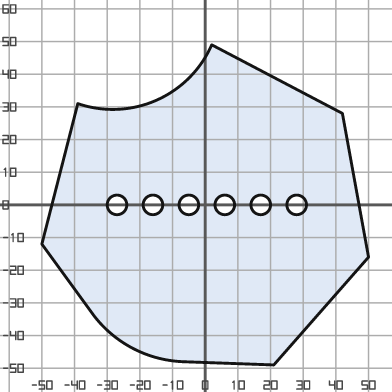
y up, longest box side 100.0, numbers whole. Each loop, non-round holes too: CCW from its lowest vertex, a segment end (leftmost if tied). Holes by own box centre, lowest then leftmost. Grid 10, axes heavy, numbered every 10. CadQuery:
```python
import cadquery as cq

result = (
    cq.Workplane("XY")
    .moveTo(21.0, -49.0)
    .lineTo(50.0, -16.0)
    .lineTo(42.0, 28.0)
    .lineTo(2.0, 49.0)
    .threePointArc((-15.0, 32.0), (-39.0, 31.0))
    .lineTo(-50.0, -12.0)
    .lineTo(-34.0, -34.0)
    .threePointArc((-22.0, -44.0), (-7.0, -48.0))
    .close()
    .moveTo(-27.0, 0.0)
    .circle(3.0)
    .moveTo(-16.0, 0.0)
    .circle(3.0)
    .moveTo(-5.0, 0.0)
    .circle(3.0)
    .moveTo(6.0, 0.0)
    .circle(3.0)
    .moveTo(17.0, 0.0)
    .circle(3.0)
    .moveTo(28.0, 0.0)
    .circle(3.0)
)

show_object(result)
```